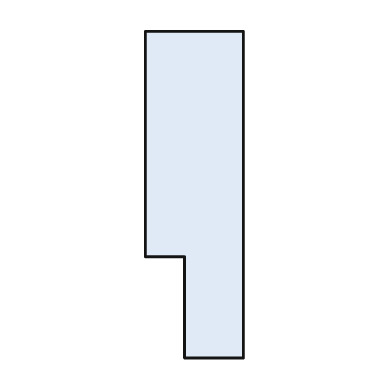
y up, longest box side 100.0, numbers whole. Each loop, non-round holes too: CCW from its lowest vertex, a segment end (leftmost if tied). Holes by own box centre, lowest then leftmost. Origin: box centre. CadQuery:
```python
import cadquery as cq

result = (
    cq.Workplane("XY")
    .moveTo(-3.0, -50.0)
    .lineTo(15.0, -50.0)
    .lineTo(15.0, 50.0)
    .lineTo(-15.0, 50.0)
    .lineTo(-15.0, -19.0)
    .lineTo(-3.0, -19.0)
    .close()
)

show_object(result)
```